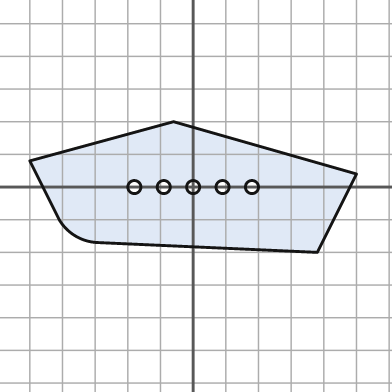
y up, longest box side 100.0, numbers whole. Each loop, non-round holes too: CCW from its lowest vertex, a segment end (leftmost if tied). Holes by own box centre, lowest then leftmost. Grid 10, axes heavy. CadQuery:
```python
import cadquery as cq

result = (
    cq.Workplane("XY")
    .moveTo(38.0, -20.0)
    .lineTo(50.0, 4.0)
    .lineTo(-6.0, 20.0)
    .lineTo(-50.0, 8.0)
    .lineTo(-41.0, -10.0)
    .threePointArc((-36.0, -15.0), (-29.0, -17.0))
    .close()
    .moveTo(-18.0, 0.0)
    .circle(2.0)
    .moveTo(-9.0, 0.0)
    .circle(2.0)
    .moveTo(0.0, 0.0)
    .circle(2.0)
    .moveTo(9.0, 0.0)
    .circle(2.0)
    .moveTo(18.0, 0.0)
    .circle(2.0)
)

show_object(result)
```